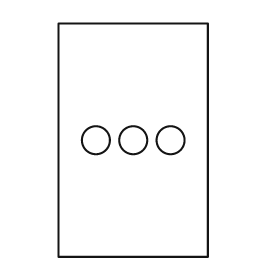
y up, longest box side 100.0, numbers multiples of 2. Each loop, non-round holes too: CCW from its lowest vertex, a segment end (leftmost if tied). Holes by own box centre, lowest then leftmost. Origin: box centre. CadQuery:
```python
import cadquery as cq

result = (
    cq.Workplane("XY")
    .moveTo(-32.0, -50.0)
    .lineTo(32.0, -50.0)
    .lineTo(32.0, 50.0)
    .lineTo(-32.0, 50.0)
    .close()
    .moveTo(-16.0, 0.0)
    .circle(6.0)
    .moveTo(0.0, 0.0)
    .circle(6.0)
    .moveTo(16.0, 0.0)
    .circle(6.0)
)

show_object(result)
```